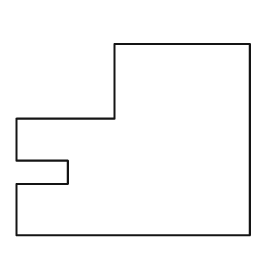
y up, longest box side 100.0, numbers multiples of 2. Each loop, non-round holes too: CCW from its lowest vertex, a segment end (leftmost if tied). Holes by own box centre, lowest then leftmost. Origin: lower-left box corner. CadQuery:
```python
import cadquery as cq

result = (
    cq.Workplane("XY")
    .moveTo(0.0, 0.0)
    .lineTo(100.0, 0.0)
    .lineTo(100.0, 82.0)
    .lineTo(42.0, 82.0)
    .lineTo(42.0, 50.0)
    .lineTo(0.0, 50.0)
    .lineTo(0.0, 32.0)
    .lineTo(22.0, 32.0)
    .lineTo(22.0, 22.0)
    .lineTo(0.0, 22.0)
    .close()
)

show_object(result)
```